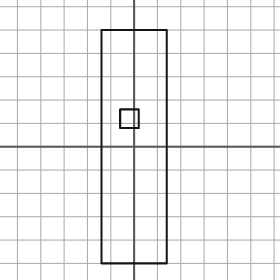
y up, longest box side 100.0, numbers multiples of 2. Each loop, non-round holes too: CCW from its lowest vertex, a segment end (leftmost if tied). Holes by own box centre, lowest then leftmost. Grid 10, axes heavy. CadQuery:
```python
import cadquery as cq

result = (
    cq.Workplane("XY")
    .moveTo(-14.0, -50.0)
    .lineTo(14.0, -50.0)
    .lineTo(14.0, 50.0)
    .lineTo(-14.0, 50.0)
    .close()
    .moveTo(-6.0, 8.0)
    .lineTo(2.0, 8.0)
    .lineTo(2.0, 16.0)
    .lineTo(-6.0, 16.0)
    .close()
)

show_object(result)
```